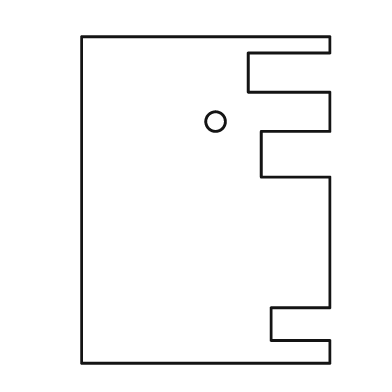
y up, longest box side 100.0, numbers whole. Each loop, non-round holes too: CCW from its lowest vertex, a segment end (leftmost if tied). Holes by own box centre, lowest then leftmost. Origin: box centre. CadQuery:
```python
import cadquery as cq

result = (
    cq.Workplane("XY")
    .moveTo(-38.0, -50.0)
    .lineTo(38.0, -50.0)
    .lineTo(38.0, -43.0)
    .lineTo(20.0, -43.0)
    .lineTo(20.0, -33.0)
    .lineTo(38.0, -33.0)
    .lineTo(38.0, 7.0)
    .lineTo(17.0, 7.0)
    .lineTo(17.0, 21.0)
    .lineTo(38.0, 21.0)
    .lineTo(38.0, 33.0)
    .lineTo(13.0, 33.0)
    .lineTo(13.0, 45.0)
    .lineTo(38.0, 45.0)
    .lineTo(38.0, 50.0)
    .lineTo(-38.0, 50.0)
    .close()
    .moveTo(3.0, 24.0)
    .circle(3.0)
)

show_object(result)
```